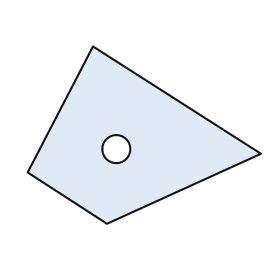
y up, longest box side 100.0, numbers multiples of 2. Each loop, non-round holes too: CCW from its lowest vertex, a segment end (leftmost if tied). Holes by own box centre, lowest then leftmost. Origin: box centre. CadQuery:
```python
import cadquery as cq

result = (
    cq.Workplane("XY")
    .moveTo(-16.0, -38.0)
    .lineTo(50.0, -8.0)
    .lineTo(-22.0, 38.0)
    .lineTo(-50.0, -16.0)
    .close()
    .moveTo(-12.0, -6.0)
    .circle(6.0)
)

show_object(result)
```